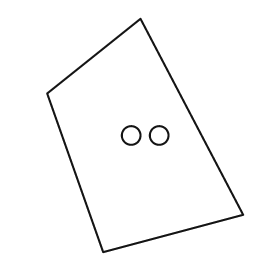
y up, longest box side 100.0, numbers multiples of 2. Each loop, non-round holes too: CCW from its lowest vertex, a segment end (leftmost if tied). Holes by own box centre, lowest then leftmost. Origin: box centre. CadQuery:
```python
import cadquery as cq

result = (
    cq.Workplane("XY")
    .moveTo(-18.0, -50.0)
    .lineTo(42.0, -34.0)
    .lineTo(-2.0, 50.0)
    .lineTo(-42.0, 18.0)
    .close()
    .moveTo(-6.0, 0.0)
    .circle(4.0)
    .moveTo(6.0, 0.0)
    .circle(4.0)
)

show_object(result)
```